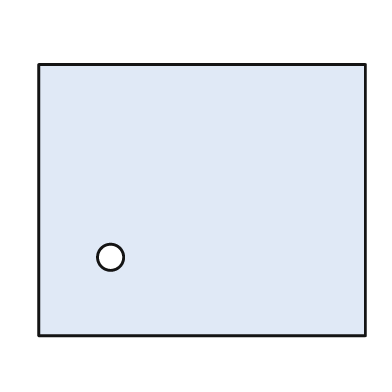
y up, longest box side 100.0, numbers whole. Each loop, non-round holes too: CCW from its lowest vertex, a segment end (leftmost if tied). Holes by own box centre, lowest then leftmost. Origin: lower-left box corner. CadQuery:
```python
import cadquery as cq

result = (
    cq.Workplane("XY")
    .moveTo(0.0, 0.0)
    .lineTo(100.0, 0.0)
    .lineTo(100.0, 83.0)
    .lineTo(0.0, 83.0)
    .close()
    .moveTo(22.0, 24.0)
    .circle(4.0)
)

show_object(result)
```